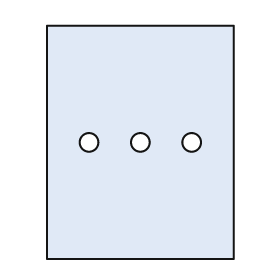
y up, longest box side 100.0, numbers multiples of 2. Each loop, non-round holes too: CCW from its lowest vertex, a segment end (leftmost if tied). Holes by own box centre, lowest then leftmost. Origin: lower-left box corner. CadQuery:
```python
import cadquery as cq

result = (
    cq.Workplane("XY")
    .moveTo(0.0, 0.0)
    .lineTo(80.0, 0.0)
    .lineTo(80.0, 100.0)
    .lineTo(0.0, 100.0)
    .close()
    .moveTo(18.0, 50.0)
    .circle(4.0)
    .moveTo(40.0, 50.0)
    .circle(4.0)
    .moveTo(62.0, 50.0)
    .circle(4.0)
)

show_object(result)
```